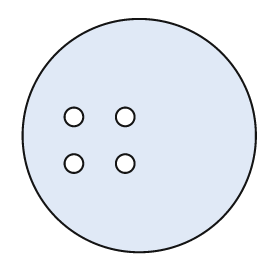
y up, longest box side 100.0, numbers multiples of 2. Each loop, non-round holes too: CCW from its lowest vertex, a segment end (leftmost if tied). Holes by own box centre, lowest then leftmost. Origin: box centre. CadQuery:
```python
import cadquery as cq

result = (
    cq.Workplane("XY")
    .moveTo(0.0, 0.0)
    .circle(50.0)
    .moveTo(-28.0, -12.0)
    .circle(4.0)
    .moveTo(-6.0, -12.0)
    .circle(4.0)
    .moveTo(-28.0, 8.0)
    .circle(4.0)
    .moveTo(-6.0, 8.0)
    .circle(4.0)
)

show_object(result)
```